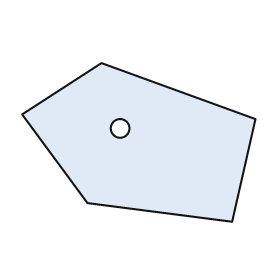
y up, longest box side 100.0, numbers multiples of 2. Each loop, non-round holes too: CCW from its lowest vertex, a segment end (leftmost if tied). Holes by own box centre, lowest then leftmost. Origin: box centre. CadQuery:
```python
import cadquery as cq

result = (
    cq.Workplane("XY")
    .moveTo(40.0, -34.0)
    .lineTo(50.0, 10.0)
    .lineTo(-16.0, 34.0)
    .lineTo(-50.0, 12.0)
    .lineTo(-22.0, -26.0)
    .close()
    .moveTo(-8.0, 6.0)
    .circle(4.0)
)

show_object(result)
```